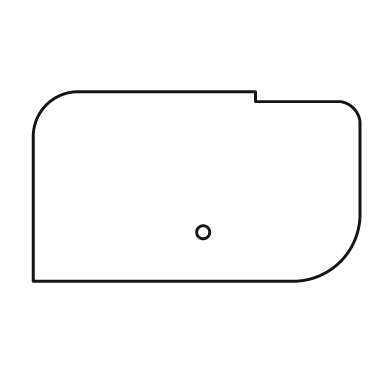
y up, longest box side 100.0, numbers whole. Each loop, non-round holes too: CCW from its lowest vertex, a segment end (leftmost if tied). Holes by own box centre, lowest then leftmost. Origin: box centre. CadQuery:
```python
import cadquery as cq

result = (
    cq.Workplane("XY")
    .moveTo(-50.0, -29.0)
    .lineTo(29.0, -29.0)
    .threePointArc((44.0, -23.0), (50.0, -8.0))
    .lineTo(50.0, 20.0)
    .threePointArc((48.0, 24.0), (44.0, 26.0))
    .lineTo(18.0, 26.0)
    .lineTo(18.0, 29.0)
    .lineTo(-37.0, 29.0)
    .threePointArc((-46.0, 25.0), (-50.0, 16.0))
    .close()
    .moveTo(2.0, -14.0)
    .circle(2.0)
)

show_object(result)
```